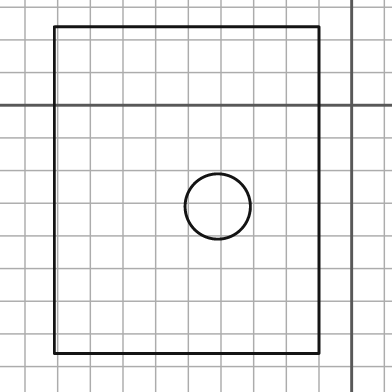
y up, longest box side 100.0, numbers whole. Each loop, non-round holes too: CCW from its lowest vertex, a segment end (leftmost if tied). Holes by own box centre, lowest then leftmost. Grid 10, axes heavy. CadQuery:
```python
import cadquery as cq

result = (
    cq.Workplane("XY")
    .moveTo(-91.0, -76.0)
    .lineTo(-10.0, -76.0)
    .lineTo(-10.0, 24.0)
    .lineTo(-91.0, 24.0)
    .close()
    .moveTo(-41.0, -31.0)
    .circle(10.0)
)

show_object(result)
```